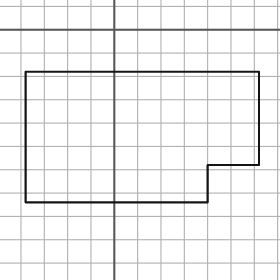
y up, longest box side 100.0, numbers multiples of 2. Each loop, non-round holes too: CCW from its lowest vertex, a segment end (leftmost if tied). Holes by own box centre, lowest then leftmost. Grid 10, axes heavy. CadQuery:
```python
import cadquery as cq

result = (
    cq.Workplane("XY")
    .moveTo(-38.0, -74.0)
    .lineTo(40.0, -74.0)
    .lineTo(40.0, -58.0)
    .lineTo(62.0, -58.0)
    .lineTo(62.0, -18.0)
    .lineTo(-38.0, -18.0)
    .close()
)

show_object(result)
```